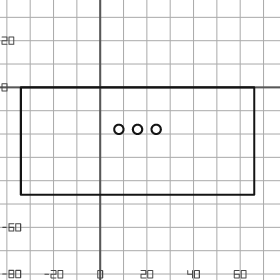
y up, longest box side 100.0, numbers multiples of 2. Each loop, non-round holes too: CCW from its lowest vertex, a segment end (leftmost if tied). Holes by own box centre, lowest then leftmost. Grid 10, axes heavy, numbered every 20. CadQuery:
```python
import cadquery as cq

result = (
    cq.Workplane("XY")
    .moveTo(-34.0, -46.0)
    .lineTo(66.0, -46.0)
    .lineTo(66.0, 0.0)
    .lineTo(-34.0, 0.0)
    .close()
    .moveTo(8.0, -18.0)
    .circle(2.0)
    .moveTo(16.0, -18.0)
    .circle(2.0)
    .moveTo(24.0, -18.0)
    .circle(2.0)
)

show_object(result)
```